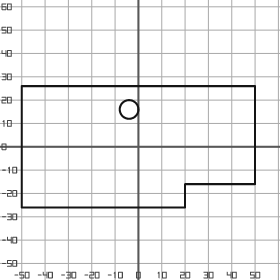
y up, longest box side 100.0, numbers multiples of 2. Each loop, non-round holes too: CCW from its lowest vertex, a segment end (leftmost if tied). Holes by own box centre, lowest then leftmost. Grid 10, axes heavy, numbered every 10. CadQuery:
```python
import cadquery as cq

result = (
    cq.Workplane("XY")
    .moveTo(-50.0, -26.0)
    .lineTo(20.0, -26.0)
    .lineTo(20.0, -16.0)
    .lineTo(50.0, -16.0)
    .lineTo(50.0, 26.0)
    .lineTo(-50.0, 26.0)
    .close()
    .moveTo(-4.0, 16.0)
    .circle(4.0)
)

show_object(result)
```